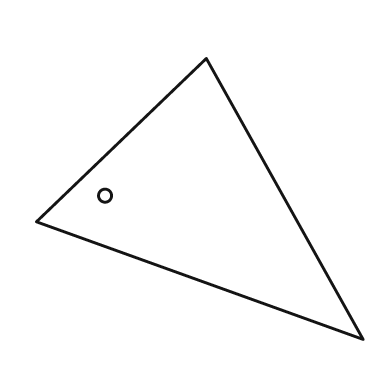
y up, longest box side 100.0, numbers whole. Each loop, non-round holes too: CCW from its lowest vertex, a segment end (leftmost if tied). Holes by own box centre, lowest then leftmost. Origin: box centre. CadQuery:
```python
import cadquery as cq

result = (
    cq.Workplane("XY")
    .moveTo(50.0, -43.0)
    .lineTo(2.0, 43.0)
    .lineTo(-50.0, -7.0)
    .close()
    .moveTo(-29.0, 1.0)
    .circle(2.0)
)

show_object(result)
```